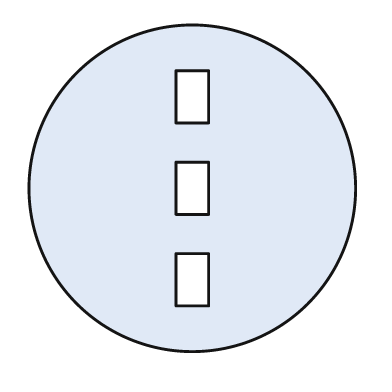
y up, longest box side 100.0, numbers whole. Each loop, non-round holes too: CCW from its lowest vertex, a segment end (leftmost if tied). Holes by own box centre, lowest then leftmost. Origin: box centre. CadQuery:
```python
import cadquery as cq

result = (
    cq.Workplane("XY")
    .moveTo(0.0, 0.0)
    .circle(50.0)
    .moveTo(-5.0, -36.0)
    .lineTo(5.0, -36.0)
    .lineTo(5.0, -20.0)
    .lineTo(-5.0, -20.0)
    .close()
    .moveTo(-5.0, -8.0)
    .lineTo(5.0, -8.0)
    .lineTo(5.0, 8.0)
    .lineTo(-5.0, 8.0)
    .close()
    .moveTo(-5.0, 20.0)
    .lineTo(5.0, 20.0)
    .lineTo(5.0, 36.0)
    .lineTo(-5.0, 36.0)
    .close()
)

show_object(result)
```